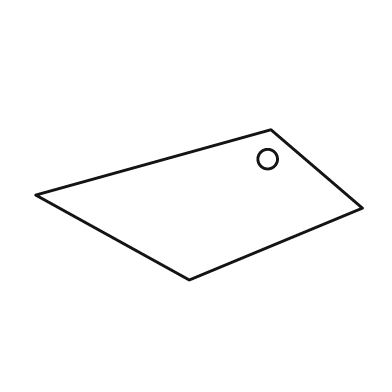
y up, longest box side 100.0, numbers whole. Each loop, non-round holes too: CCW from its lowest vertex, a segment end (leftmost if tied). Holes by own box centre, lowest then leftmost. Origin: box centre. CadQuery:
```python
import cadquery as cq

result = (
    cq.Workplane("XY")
    .moveTo(-3.0, -23.0)
    .lineTo(50.0, -1.0)
    .lineTo(22.0, 23.0)
    .lineTo(-50.0, 3.0)
    .close()
    .moveTo(21.0, 14.0)
    .circle(3.0)
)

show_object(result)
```